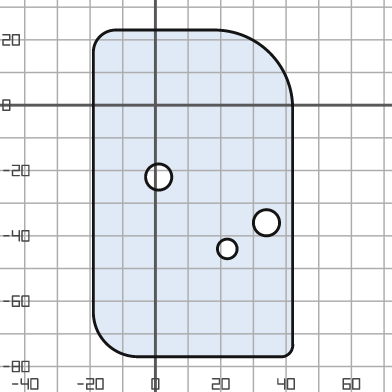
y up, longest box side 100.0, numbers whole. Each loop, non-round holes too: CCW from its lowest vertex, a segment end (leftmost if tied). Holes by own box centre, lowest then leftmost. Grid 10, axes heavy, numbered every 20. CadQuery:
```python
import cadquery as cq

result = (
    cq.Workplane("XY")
    .moveTo(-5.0, -77.0)
    .lineTo(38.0, -77.0)
    .threePointArc((41.0, -76.0), (42.0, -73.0))
    .lineTo(42.0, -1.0)
    .threePointArc((35.0, 16.0), (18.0, 23.0))
    .lineTo(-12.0, 23.0)
    .threePointArc((-17.0, 21.0), (-19.0, 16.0))
    .lineTo(-19.0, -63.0)
    .threePointArc((-15.0, -73.0), (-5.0, -77.0))
    .close()
    .moveTo(22.0, -44.0)
    .circle(3.0)
    .moveTo(34.0, -36.0)
    .circle(4.0)
    .moveTo(1.0, -22.0)
    .circle(4.0)
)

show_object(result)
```